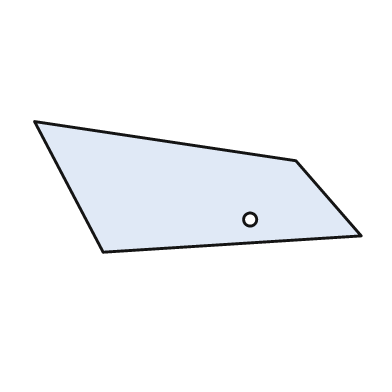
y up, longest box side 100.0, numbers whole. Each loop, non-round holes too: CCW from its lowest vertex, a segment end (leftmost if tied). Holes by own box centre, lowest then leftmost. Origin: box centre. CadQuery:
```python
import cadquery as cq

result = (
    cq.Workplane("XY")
    .moveTo(-29.0, -20.0)
    .lineTo(50.0, -15.0)
    .lineTo(30.0, 8.0)
    .lineTo(-50.0, 20.0)
    .close()
    .moveTo(16.0, -10.0)
    .circle(2.0)
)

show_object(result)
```